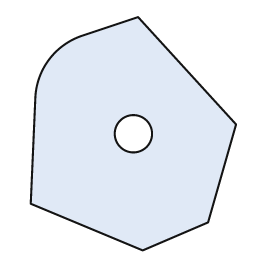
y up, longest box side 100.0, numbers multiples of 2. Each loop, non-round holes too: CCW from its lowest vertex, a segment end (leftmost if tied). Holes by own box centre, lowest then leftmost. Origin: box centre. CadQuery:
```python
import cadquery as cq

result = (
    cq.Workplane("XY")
    .moveTo(4.0, -50.0)
    .lineTo(32.0, -38.0)
    .lineTo(44.0, 4.0)
    .lineTo(2.0, 50.0)
    .lineTo(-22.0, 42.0)
    .threePointArc((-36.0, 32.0), (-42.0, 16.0))
    .lineTo(-44.0, -30.0)
    .close()
    .moveTo(0.0, 0.0)
    .circle(8.0)
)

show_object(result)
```